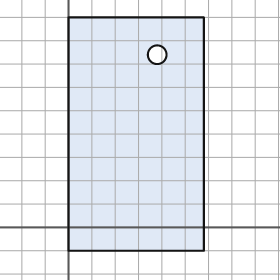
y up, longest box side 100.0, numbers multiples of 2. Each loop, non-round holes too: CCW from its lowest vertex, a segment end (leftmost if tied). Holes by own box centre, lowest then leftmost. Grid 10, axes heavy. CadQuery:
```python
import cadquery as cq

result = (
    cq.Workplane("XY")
    .moveTo(0.0, -10.0)
    .lineTo(58.0, -10.0)
    .lineTo(58.0, 90.0)
    .lineTo(0.0, 90.0)
    .close()
    .moveTo(38.0, 74.0)
    .circle(4.0)
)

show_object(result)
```